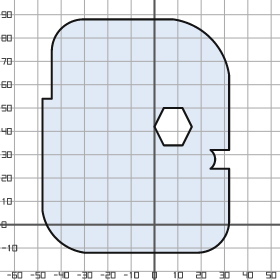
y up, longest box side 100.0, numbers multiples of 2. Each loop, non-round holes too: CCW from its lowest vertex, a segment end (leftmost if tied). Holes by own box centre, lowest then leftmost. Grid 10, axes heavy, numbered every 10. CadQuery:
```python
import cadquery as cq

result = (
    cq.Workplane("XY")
    .moveTo(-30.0, -12.0)
    .lineTo(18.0, -12.0)
    .threePointArc((28.0, -8.0), (32.0, 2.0))
    .lineTo(32.0, 24.0)
    .lineTo(24.0, 24.0)
    .threePointArc((26.0, 28.0), (24.0, 32.0))
    .lineTo(32.0, 32.0)
    .lineTo(32.0, 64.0)
    .threePointArc((24.0, 80.0), (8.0, 88.0))
    .lineTo(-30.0, 88.0)
    .threePointArc((-40.0, 84.0), (-44.0, 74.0))
    .lineTo(-44.0, 54.0)
    .lineTo(-48.0, 54.0)
    .lineTo(-48.0, 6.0)
    .threePointArc((-42.0, -6.0), (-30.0, -12.0))
    .close()
    .moveTo(4.0, 34.0)
    .lineTo(12.0, 34.0)
    .lineTo(16.0, 42.0)
    .lineTo(12.0, 50.0)
    .lineTo(4.0, 50.0)
    .lineTo(0.0, 42.0)
    .close()
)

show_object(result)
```